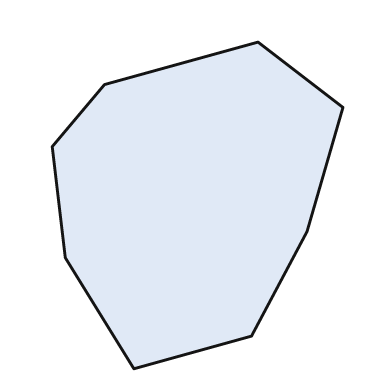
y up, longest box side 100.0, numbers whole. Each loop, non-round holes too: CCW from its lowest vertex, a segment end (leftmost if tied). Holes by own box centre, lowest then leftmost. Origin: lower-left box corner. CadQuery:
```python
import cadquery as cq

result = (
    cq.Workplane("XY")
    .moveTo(25.0, 0.0)
    .lineTo(61.0, 10.0)
    .lineTo(78.0, 42.0)
    .lineTo(89.0, 80.0)
    .lineTo(63.0, 100.0)
    .lineTo(16.0, 87.0)
    .lineTo(0.0, 68.0)
    .lineTo(4.0, 34.0)
    .close()
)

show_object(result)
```